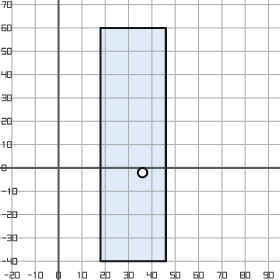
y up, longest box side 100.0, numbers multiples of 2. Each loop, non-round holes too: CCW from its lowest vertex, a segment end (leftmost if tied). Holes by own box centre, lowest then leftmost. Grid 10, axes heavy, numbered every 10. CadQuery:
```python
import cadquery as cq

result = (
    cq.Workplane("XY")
    .moveTo(18.0, -40.0)
    .lineTo(46.0, -40.0)
    .lineTo(46.0, 60.0)
    .lineTo(18.0, 60.0)
    .close()
    .moveTo(36.0, -2.0)
    .circle(2.0)
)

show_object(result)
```